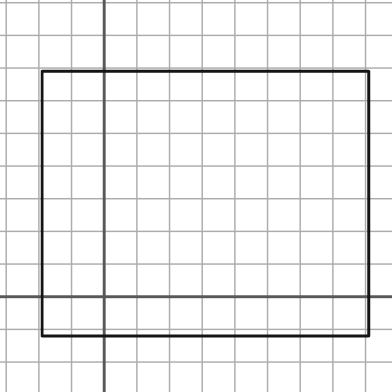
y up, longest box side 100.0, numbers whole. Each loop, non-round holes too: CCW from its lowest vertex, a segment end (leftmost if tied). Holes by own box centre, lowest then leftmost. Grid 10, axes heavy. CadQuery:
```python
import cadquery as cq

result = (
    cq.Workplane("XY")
    .moveTo(-19.0, -12.0)
    .lineTo(81.0, -12.0)
    .lineTo(81.0, 69.0)
    .lineTo(-19.0, 69.0)
    .close()
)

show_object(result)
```